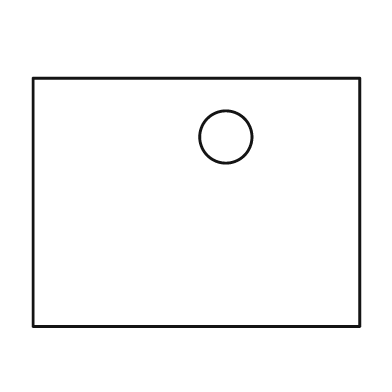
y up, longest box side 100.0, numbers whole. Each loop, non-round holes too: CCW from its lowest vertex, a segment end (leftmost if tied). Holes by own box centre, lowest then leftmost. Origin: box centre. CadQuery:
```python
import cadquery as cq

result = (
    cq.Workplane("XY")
    .moveTo(-50.0, -38.0)
    .lineTo(50.0, -38.0)
    .lineTo(50.0, 38.0)
    .lineTo(-50.0, 38.0)
    .close()
    .moveTo(9.0, 20.0)
    .circle(8.0)
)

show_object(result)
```